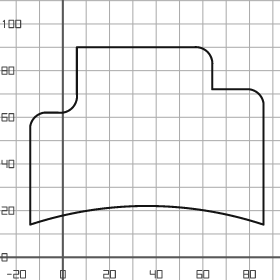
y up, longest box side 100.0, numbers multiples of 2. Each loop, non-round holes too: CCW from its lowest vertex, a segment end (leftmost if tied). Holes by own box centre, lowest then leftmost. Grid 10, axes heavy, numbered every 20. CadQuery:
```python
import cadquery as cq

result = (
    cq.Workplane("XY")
    .moveTo(-14.0, 14.0)
    .threePointArc((36.0, 22.0), (86.0, 14.0))
    .lineTo(86.0, 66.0)
    .threePointArc((84.0, 70.0), (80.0, 72.0))
    .lineTo(64.0, 72.0)
    .lineTo(64.0, 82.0)
    .threePointArc((62.0, 88.0), (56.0, 90.0))
    .lineTo(6.0, 90.0)
    .lineTo(6.0, 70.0)
    .threePointArc((4.0, 64.0), (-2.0, 62.0))
    .lineTo(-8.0, 62.0)
    .threePointArc((-12.0, 60.0), (-14.0, 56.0))
    .close()
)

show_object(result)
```